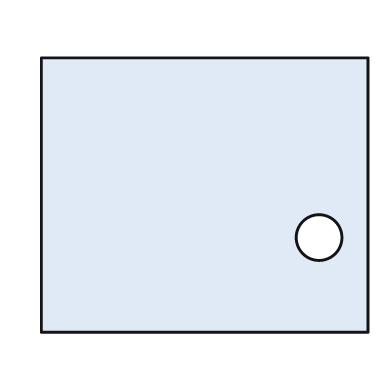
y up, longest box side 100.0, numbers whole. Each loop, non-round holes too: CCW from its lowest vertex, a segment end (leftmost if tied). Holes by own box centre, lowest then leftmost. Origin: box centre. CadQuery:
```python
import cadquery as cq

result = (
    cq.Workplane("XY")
    .moveTo(-50.0, -42.0)
    .lineTo(50.0, -42.0)
    .lineTo(50.0, 42.0)
    .lineTo(-50.0, 42.0)
    .close()
    .moveTo(35.0, -13.0)
    .circle(7.0)
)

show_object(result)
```